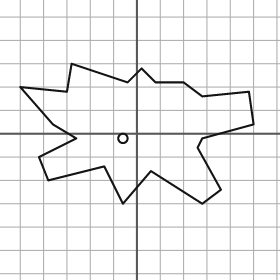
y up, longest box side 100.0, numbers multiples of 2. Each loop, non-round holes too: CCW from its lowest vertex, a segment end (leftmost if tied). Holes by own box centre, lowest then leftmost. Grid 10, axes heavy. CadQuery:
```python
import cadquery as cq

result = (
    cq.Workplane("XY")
    .moveTo(-6.0, -30.0)
    .lineTo(6.0, -16.0)
    .lineTo(28.0, -30.0)
    .lineTo(36.0, -24.0)
    .lineTo(26.0, -6.0)
    .lineTo(28.0, -2.0)
    .lineTo(50.0, 4.0)
    .lineTo(48.0, 18.0)
    .lineTo(28.0, 16.0)
    .lineTo(20.0, 22.0)
    .lineTo(8.0, 22.0)
    .lineTo(2.0, 28.0)
    .lineTo(-4.0, 22.0)
    .lineTo(-28.0, 30.0)
    .lineTo(-30.0, 18.0)
    .lineTo(-50.0, 20.0)
    .lineTo(-36.0, 4.0)
    .lineTo(-26.0, -2.0)
    .lineTo(-42.0, -10.0)
    .lineTo(-38.0, -20.0)
    .lineTo(-14.0, -14.0)
    .close()
    .moveTo(-6.0, -2.0)
    .circle(2.0)
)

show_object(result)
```